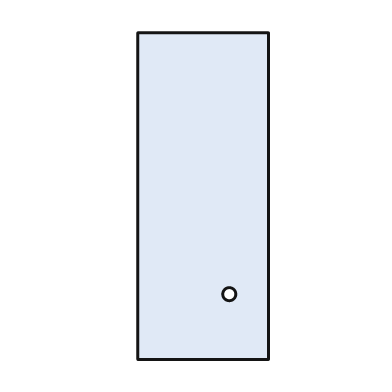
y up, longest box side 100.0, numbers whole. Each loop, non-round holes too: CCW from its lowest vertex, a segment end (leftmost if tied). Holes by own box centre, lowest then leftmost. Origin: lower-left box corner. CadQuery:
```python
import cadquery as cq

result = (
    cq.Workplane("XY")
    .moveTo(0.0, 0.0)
    .lineTo(40.0, 0.0)
    .lineTo(40.0, 100.0)
    .lineTo(0.0, 100.0)
    .close()
    .moveTo(28.0, 20.0)
    .circle(2.0)
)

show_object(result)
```